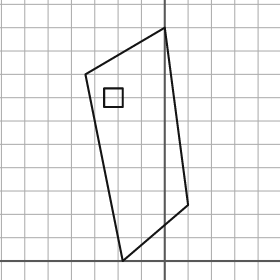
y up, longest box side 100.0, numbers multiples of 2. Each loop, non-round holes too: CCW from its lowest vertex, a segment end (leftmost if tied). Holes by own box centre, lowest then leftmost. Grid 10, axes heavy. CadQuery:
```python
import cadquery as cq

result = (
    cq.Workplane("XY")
    .moveTo(-18.0, 0.0)
    .lineTo(10.0, 24.0)
    .lineTo(0.0, 100.0)
    .lineTo(-34.0, 80.0)
    .close()
    .moveTo(-26.0, 66.0)
    .lineTo(-18.0, 66.0)
    .lineTo(-18.0, 74.0)
    .lineTo(-26.0, 74.0)
    .close()
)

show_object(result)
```